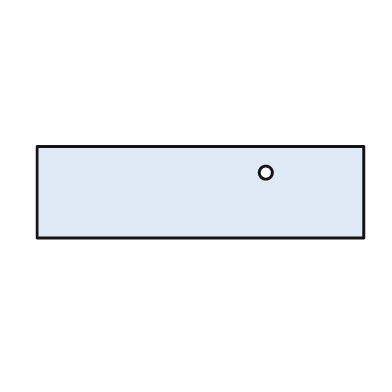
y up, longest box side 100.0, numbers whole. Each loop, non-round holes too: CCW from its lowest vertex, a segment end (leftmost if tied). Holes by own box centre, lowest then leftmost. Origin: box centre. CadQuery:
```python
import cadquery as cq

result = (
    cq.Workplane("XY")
    .moveTo(-50.0, -14.0)
    .lineTo(50.0, -14.0)
    .lineTo(50.0, 14.0)
    .lineTo(-50.0, 14.0)
    .close()
    .moveTo(20.0, 6.0)
    .circle(2.0)
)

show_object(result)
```